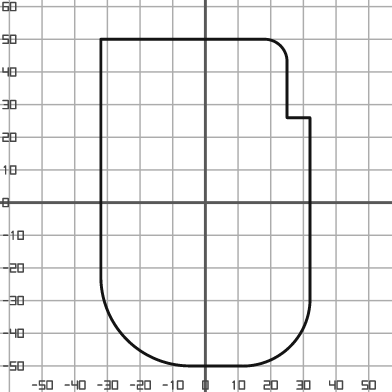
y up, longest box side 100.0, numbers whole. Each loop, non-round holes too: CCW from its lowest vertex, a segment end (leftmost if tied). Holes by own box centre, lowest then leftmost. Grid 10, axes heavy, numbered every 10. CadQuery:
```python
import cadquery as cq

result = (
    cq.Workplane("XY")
    .moveTo(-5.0, -50.0)
    .lineTo(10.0, -50.0)
    .threePointArc((26.0, -44.0), (32.0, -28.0))
    .lineTo(32.0, 26.0)
    .lineTo(25.0, 26.0)
    .lineTo(25.0, 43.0)
    .threePointArc((23.0, 48.0), (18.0, 50.0))
    .lineTo(-32.0, 50.0)
    .lineTo(-32.0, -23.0)
    .threePointArc((-24.0, -42.0), (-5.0, -50.0))
    .close()
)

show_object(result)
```